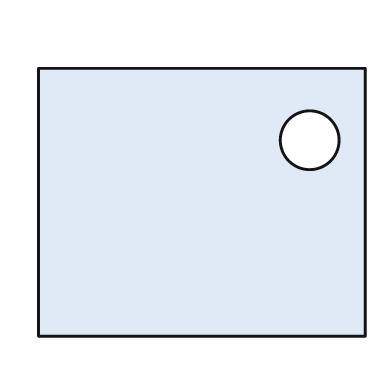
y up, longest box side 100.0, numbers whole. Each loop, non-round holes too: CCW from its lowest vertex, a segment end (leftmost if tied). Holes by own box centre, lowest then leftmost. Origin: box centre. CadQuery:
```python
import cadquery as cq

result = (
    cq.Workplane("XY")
    .moveTo(-50.0, -41.0)
    .lineTo(50.0, -41.0)
    .lineTo(50.0, 41.0)
    .lineTo(-50.0, 41.0)
    .close()
    .moveTo(33.0, 19.0)
    .circle(9.0)
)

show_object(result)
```